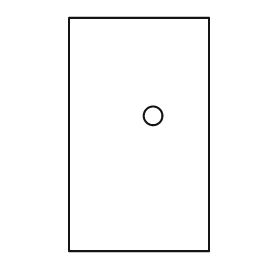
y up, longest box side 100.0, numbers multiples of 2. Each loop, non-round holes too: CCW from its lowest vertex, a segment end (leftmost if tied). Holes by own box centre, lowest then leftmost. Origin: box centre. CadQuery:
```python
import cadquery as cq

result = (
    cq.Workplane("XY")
    .moveTo(-30.0, -50.0)
    .lineTo(30.0, -50.0)
    .lineTo(30.0, 50.0)
    .lineTo(-30.0, 50.0)
    .close()
    .moveTo(6.0, 8.0)
    .circle(4.0)
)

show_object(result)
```